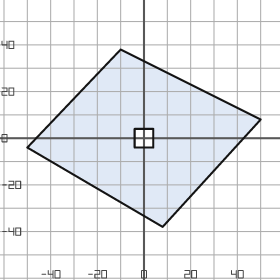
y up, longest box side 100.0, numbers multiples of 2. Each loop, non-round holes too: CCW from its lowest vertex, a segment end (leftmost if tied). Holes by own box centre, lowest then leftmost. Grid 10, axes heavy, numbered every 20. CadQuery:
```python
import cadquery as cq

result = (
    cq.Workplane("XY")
    .moveTo(8.0, -38.0)
    .lineTo(50.0, 8.0)
    .lineTo(-10.0, 38.0)
    .lineTo(-50.0, -4.0)
    .close()
    .moveTo(-4.0, -4.0)
    .lineTo(4.0, -4.0)
    .lineTo(4.0, 4.0)
    .lineTo(-4.0, 4.0)
    .close()
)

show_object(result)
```